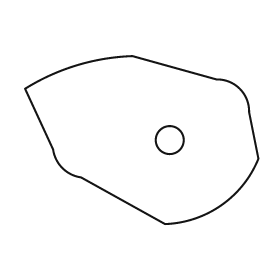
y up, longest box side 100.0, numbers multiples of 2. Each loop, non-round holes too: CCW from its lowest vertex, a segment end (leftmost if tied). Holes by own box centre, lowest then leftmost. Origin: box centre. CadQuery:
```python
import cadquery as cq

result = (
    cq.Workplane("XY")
    .moveTo(10.0, -36.0)
    .threePointArc((34.0, -28.0), (50.0, -8.0))
    .lineTo(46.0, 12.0)
    .threePointArc((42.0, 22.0), (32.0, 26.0))
    .lineTo(-4.0, 36.0)
    .threePointArc((-28.0, 32.0), (-50.0, 22.0))
    .lineTo(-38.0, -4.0)
    .threePointArc((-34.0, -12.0), (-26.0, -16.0))
    .close()
    .moveTo(12.0, 0.0)
    .circle(6.0)
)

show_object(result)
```